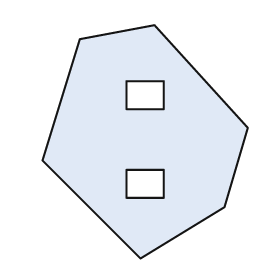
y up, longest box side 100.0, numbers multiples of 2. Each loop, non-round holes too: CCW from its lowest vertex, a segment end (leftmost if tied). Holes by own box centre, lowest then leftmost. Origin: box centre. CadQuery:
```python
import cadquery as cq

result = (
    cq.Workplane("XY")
    .moveTo(-2.0, -50.0)
    .lineTo(34.0, -28.0)
    .lineTo(44.0, 6.0)
    .lineTo(4.0, 50.0)
    .lineTo(-28.0, 44.0)
    .lineTo(-44.0, -8.0)
    .close()
    .moveTo(-8.0, -24.0)
    .lineTo(8.0, -24.0)
    .lineTo(8.0, -12.0)
    .lineTo(-8.0, -12.0)
    .close()
    .moveTo(-8.0, 14.0)
    .lineTo(8.0, 14.0)
    .lineTo(8.0, 26.0)
    .lineTo(-8.0, 26.0)
    .close()
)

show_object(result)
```